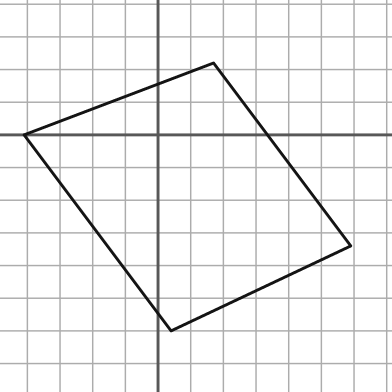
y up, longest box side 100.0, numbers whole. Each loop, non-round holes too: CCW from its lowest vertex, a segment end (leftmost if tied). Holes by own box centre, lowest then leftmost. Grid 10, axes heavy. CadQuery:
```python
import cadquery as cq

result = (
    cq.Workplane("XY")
    .moveTo(4.0, -60.0)
    .lineTo(59.0, -34.0)
    .lineTo(17.0, 22.0)
    .lineTo(-41.0, 0.0)
    .close()
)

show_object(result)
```